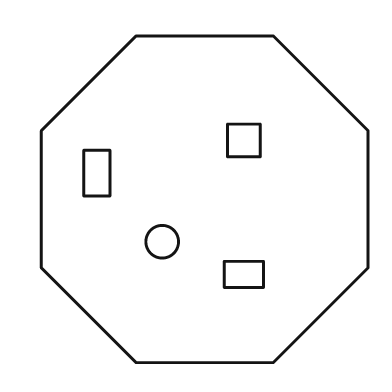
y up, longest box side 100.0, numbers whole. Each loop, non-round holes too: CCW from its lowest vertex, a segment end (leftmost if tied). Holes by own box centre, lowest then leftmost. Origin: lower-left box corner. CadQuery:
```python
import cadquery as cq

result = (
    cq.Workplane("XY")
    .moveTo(29.0, 0.0)
    .lineTo(71.0, 0.0)
    .lineTo(100.0, 29.0)
    .lineTo(100.0, 71.0)
    .lineTo(71.0, 100.0)
    .lineTo(29.0, 100.0)
    .lineTo(0.0, 71.0)
    .lineTo(0.0, 29.0)
    .close()
    .moveTo(56.0, 23.0)
    .lineTo(68.0, 23.0)
    .lineTo(68.0, 31.0)
    .lineTo(56.0, 31.0)
    .close()
    .moveTo(37.0, 37.0)
    .circle(5.0)
    .moveTo(13.0, 51.0)
    .lineTo(21.0, 51.0)
    .lineTo(21.0, 65.0)
    .lineTo(13.0, 65.0)
    .close()
    .moveTo(57.0, 63.0)
    .lineTo(67.0, 63.0)
    .lineTo(67.0, 73.0)
    .lineTo(57.0, 73.0)
    .close()
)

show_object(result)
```